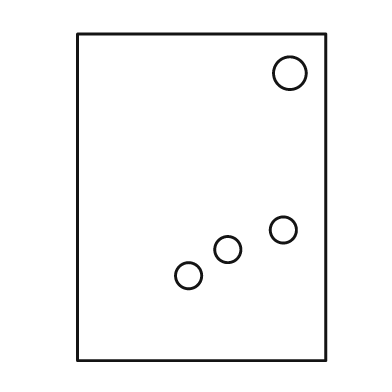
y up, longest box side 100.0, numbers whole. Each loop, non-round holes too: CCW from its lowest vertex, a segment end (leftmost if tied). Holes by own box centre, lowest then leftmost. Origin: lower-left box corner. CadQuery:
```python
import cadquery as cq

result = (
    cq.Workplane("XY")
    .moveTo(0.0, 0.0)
    .lineTo(76.0, 0.0)
    .lineTo(76.0, 100.0)
    .lineTo(0.0, 100.0)
    .close()
    .moveTo(34.0, 26.0)
    .circle(4.0)
    .moveTo(46.0, 34.0)
    .circle(4.0)
    .moveTo(63.0, 40.0)
    .circle(4.0)
    .moveTo(65.0, 88.0)
    .circle(5.0)
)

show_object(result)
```